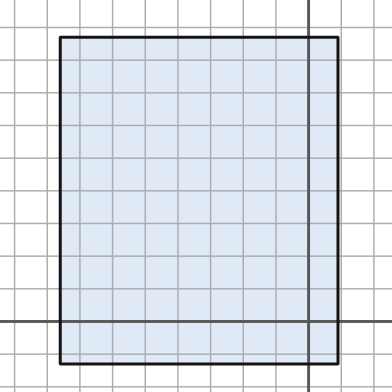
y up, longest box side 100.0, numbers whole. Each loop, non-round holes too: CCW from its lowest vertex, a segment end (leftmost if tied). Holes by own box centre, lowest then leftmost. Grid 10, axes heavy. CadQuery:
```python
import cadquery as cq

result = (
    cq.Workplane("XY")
    .moveTo(-76.0, -13.0)
    .lineTo(9.0, -13.0)
    .lineTo(9.0, 87.0)
    .lineTo(-76.0, 87.0)
    .close()
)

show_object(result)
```